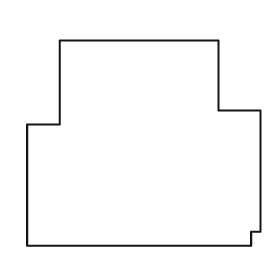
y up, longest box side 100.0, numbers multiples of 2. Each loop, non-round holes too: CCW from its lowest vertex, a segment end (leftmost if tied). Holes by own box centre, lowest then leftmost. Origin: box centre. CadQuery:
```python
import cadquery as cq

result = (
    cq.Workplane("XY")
    .moveTo(-50.0, -44.0)
    .lineTo(46.0, -44.0)
    .lineTo(46.0, -38.0)
    .lineTo(50.0, -38.0)
    .lineTo(50.0, 14.0)
    .lineTo(32.0, 14.0)
    .lineTo(32.0, 44.0)
    .lineTo(-36.0, 44.0)
    .lineTo(-36.0, 8.0)
    .lineTo(-50.0, 8.0)
    .close()
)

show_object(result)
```